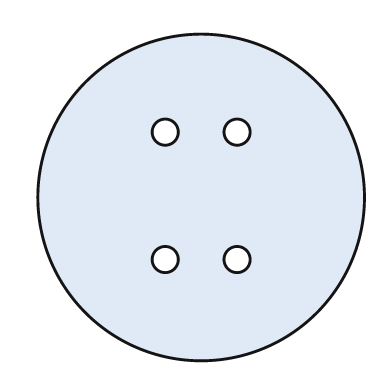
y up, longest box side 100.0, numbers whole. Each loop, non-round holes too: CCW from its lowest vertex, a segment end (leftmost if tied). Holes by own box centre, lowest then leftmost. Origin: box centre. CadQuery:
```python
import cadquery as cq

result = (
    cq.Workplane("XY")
    .moveTo(0.0, 0.0)
    .circle(50.0)
    .moveTo(-11.0, -19.0)
    .circle(4.0)
    .moveTo(11.0, -19.0)
    .circle(4.0)
    .moveTo(-11.0, 20.0)
    .circle(4.0)
    .moveTo(11.0, 20.0)
    .circle(4.0)
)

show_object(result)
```